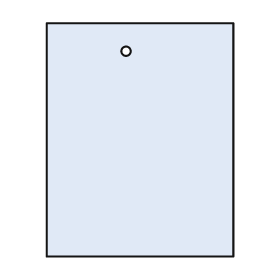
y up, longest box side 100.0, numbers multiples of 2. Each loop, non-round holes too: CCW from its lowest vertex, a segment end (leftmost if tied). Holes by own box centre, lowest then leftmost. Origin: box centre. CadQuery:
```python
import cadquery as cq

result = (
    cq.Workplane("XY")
    .moveTo(-40.0, -50.0)
    .lineTo(40.0, -50.0)
    .lineTo(40.0, 50.0)
    .lineTo(-40.0, 50.0)
    .close()
    .moveTo(-6.0, 38.0)
    .circle(2.0)
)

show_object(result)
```